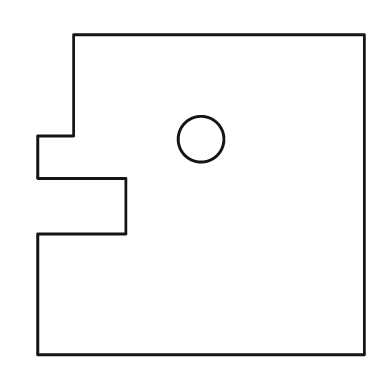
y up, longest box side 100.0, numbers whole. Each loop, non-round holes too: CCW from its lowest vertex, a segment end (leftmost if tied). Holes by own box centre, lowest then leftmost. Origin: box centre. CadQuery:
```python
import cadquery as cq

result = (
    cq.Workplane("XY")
    .moveTo(-50.0, -49.0)
    .lineTo(50.0, -49.0)
    .lineTo(50.0, 49.0)
    .lineTo(-39.0, 49.0)
    .lineTo(-39.0, 18.0)
    .lineTo(-50.0, 18.0)
    .lineTo(-50.0, 5.0)
    .lineTo(-23.0, 5.0)
    .lineTo(-23.0, -12.0)
    .lineTo(-50.0, -12.0)
    .close()
    .moveTo(0.0, 17.0)
    .circle(7.0)
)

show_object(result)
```